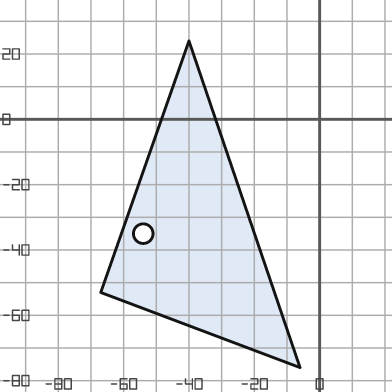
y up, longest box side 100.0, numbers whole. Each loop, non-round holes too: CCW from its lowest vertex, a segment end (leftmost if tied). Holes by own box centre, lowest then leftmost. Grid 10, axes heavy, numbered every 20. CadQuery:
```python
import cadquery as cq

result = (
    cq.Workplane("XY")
    .moveTo(-6.0, -76.0)
    .lineTo(-40.0, 24.0)
    .lineTo(-67.0, -53.0)
    .close()
    .moveTo(-54.0, -35.0)
    .circle(3.0)
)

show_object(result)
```